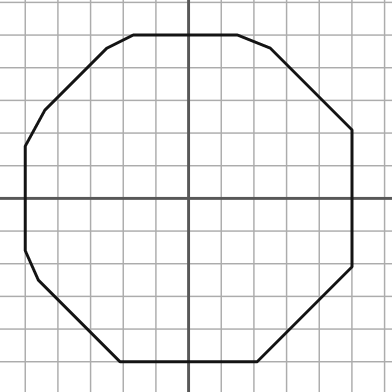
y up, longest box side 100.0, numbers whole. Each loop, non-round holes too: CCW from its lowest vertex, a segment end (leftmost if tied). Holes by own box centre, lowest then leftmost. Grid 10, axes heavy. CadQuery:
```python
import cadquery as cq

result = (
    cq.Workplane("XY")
    .moveTo(-21.0, -50.0)
    .lineTo(21.0, -50.0)
    .lineTo(50.0, -21.0)
    .lineTo(50.0, 21.0)
    .lineTo(25.0, 46.0)
    .lineTo(15.0, 50.0)
    .lineTo(-17.0, 50.0)
    .lineTo(-25.0, 46.0)
    .lineTo(-44.0, 27.0)
    .lineTo(-50.0, 16.0)
    .lineTo(-50.0, -16.0)
    .lineTo(-46.0, -25.0)
    .close()
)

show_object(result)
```